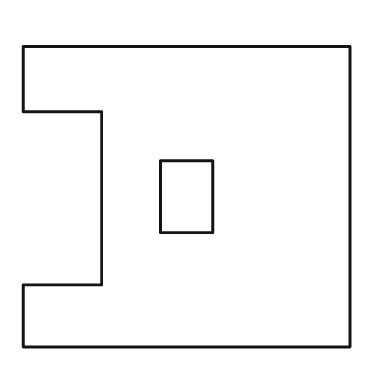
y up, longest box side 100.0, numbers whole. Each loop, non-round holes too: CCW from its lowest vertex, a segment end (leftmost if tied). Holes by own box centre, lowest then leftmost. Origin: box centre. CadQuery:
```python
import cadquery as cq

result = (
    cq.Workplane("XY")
    .moveTo(-50.0, -46.0)
    .lineTo(50.0, -46.0)
    .lineTo(50.0, 46.0)
    .lineTo(-50.0, 46.0)
    .lineTo(-50.0, 26.0)
    .lineTo(-26.0, 26.0)
    .lineTo(-26.0, -27.0)
    .lineTo(-50.0, -27.0)
    .close()
    .moveTo(-8.0, -11.0)
    .lineTo(8.0, -11.0)
    .lineTo(8.0, 11.0)
    .lineTo(-8.0, 11.0)
    .close()
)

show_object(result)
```